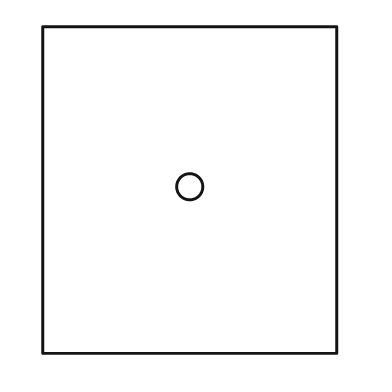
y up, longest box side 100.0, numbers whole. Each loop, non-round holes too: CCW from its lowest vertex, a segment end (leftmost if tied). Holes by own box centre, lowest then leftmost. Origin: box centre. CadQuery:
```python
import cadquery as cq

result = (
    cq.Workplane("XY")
    .moveTo(-45.0, -50.0)
    .lineTo(45.0, -50.0)
    .lineTo(45.0, 50.0)
    .lineTo(-45.0, 50.0)
    .close()
    .moveTo(0.0, 1.0)
    .circle(4.0)
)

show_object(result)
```